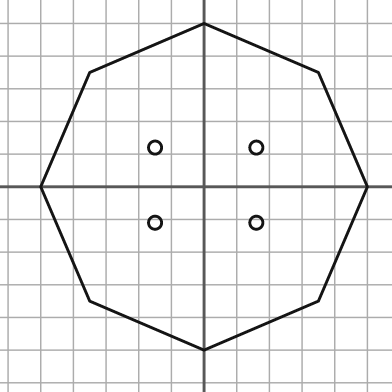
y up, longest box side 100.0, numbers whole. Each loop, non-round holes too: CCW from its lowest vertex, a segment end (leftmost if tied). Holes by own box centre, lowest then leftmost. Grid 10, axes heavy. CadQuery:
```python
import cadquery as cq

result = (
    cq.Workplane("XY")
    .moveTo(0.0, -50.0)
    .lineTo(35.0, -35.0)
    .lineTo(50.0, 0.0)
    .lineTo(35.0, 35.0)
    .lineTo(0.0, 50.0)
    .lineTo(-35.0, 35.0)
    .lineTo(-50.0, 0.0)
    .lineTo(-35.0, -35.0)
    .close()
    .moveTo(-15.0, -11.0)
    .circle(2.0)
    .moveTo(16.0, -11.0)
    .circle(2.0)
    .moveTo(-15.0, 12.0)
    .circle(2.0)
    .moveTo(16.0, 12.0)
    .circle(2.0)
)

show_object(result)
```